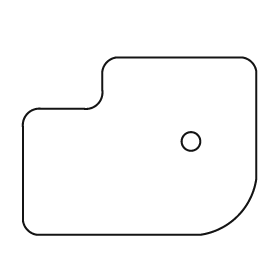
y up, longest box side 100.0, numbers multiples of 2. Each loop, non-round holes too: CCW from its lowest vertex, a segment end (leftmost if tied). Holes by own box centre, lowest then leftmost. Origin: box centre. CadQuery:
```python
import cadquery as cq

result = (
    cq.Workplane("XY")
    .moveTo(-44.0, -38.0)
    .lineTo(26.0, -38.0)
    .threePointArc((42.0, -30.0), (50.0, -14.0))
    .lineTo(50.0, 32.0)
    .threePointArc((48.0, 36.0), (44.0, 38.0))
    .lineTo(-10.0, 38.0)
    .threePointArc((-14.0, 36.0), (-16.0, 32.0))
    .lineTo(-16.0, 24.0)
    .threePointArc((-18.0, 18.0), (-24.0, 16.0))
    .lineTo(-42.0, 16.0)
    .threePointArc((-48.0, 14.0), (-50.0, 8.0))
    .lineTo(-50.0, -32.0)
    .threePointArc((-48.0, -36.0), (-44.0, -38.0))
    .close()
    .moveTo(22.0, 2.0)
    .circle(4.0)
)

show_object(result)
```